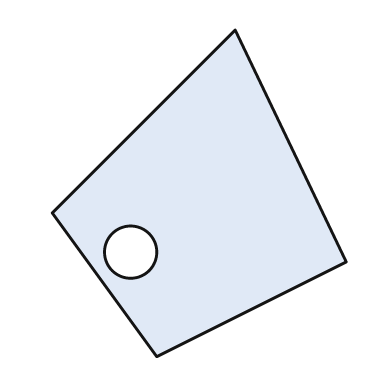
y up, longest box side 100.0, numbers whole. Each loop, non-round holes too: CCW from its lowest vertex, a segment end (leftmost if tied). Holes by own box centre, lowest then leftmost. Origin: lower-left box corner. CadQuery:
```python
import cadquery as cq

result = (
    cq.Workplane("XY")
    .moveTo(32.0, 0.0)
    .lineTo(90.0, 29.0)
    .lineTo(56.0, 100.0)
    .lineTo(0.0, 44.0)
    .close()
    .moveTo(24.0, 32.0)
    .circle(8.0)
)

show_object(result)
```